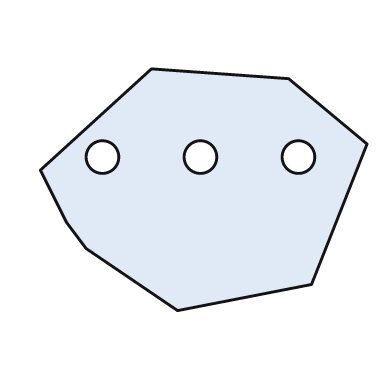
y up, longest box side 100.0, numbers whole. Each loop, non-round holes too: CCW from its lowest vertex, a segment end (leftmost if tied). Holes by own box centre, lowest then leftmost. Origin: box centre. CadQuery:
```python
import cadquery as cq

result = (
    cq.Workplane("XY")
    .moveTo(-8.0, -37.0)
    .lineTo(33.0, -29.0)
    .lineTo(50.0, 14.0)
    .lineTo(26.0, 34.0)
    .lineTo(-16.0, 37.0)
    .lineTo(-50.0, 6.0)
    .lineTo(-42.0, -10.0)
    .lineTo(-36.0, -18.0)
    .close()
    .moveTo(-31.0, 10.0)
    .circle(5.0)
    .moveTo(-1.0, 10.0)
    .circle(5.0)
    .moveTo(29.0, 10.0)
    .circle(5.0)
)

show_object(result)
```